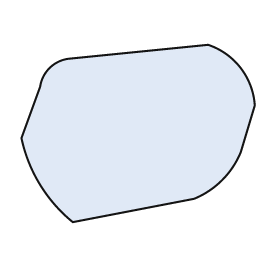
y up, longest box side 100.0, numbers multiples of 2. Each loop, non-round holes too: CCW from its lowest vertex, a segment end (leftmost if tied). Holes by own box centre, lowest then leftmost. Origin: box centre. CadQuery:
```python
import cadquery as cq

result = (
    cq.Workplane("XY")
    .moveTo(-28.0, -38.0)
    .lineTo(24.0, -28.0)
    .threePointArc((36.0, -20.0), (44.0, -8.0))
    .lineTo(50.0, 12.0)
    .threePointArc((44.0, 28.0), (30.0, 38.0))
    .lineTo(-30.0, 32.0)
    .threePointArc((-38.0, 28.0), (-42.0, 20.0))
    .lineTo(-50.0, -2.0)
    .threePointArc((-42.0, -22.0), (-28.0, -38.0))
    .close()
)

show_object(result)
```